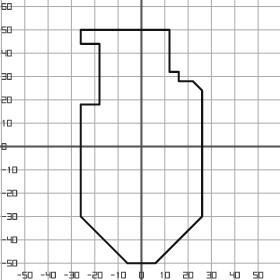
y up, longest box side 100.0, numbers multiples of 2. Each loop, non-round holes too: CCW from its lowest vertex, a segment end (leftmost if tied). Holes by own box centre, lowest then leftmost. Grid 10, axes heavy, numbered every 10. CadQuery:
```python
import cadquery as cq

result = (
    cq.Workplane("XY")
    .moveTo(-6.0, -50.0)
    .lineTo(6.0, -50.0)
    .lineTo(26.0, -30.0)
    .lineTo(26.0, 24.0)
    .lineTo(22.0, 28.0)
    .lineTo(16.0, 28.0)
    .lineTo(16.0, 32.0)
    .lineTo(12.0, 32.0)
    .lineTo(12.0, 50.0)
    .lineTo(-26.0, 50.0)
    .lineTo(-26.0, 44.0)
    .lineTo(-18.0, 44.0)
    .lineTo(-18.0, 18.0)
    .lineTo(-26.0, 18.0)
    .lineTo(-26.0, -30.0)
    .close()
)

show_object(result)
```